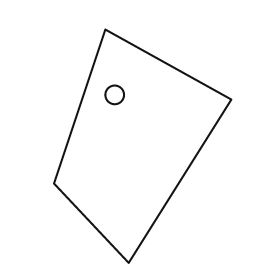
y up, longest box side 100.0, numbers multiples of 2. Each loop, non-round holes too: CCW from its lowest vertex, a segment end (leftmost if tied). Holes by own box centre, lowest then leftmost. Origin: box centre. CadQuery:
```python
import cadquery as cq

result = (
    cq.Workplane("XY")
    .moveTo(-6.0, -50.0)
    .lineTo(38.0, 20.0)
    .lineTo(-16.0, 50.0)
    .lineTo(-38.0, -16.0)
    .close()
    .moveTo(-12.0, 22.0)
    .circle(4.0)
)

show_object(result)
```